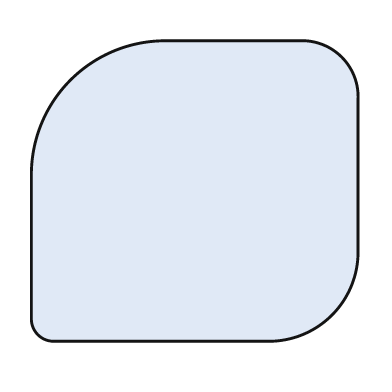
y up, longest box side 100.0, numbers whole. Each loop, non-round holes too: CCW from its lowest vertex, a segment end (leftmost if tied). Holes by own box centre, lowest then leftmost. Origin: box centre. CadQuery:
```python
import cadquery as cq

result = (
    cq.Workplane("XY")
    .moveTo(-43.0, -46.0)
    .lineTo(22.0, -46.0)
    .threePointArc((42.0, -38.0), (50.0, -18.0))
    .lineTo(50.0, 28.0)
    .threePointArc((45.0, 41.0), (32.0, 46.0))
    .lineTo(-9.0, 46.0)
    .threePointArc((-38.0, 34.0), (-50.0, 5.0))
    .lineTo(-50.0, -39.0)
    .threePointArc((-48.0, -44.0), (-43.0, -46.0))
    .close()
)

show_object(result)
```